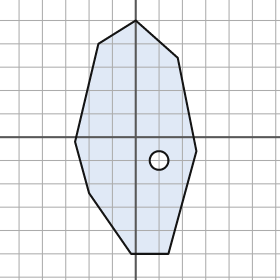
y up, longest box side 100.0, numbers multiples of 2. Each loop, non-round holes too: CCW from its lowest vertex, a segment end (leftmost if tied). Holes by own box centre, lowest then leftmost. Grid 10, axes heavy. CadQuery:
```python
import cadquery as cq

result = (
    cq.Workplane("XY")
    .moveTo(-2.0, -50.0)
    .lineTo(14.0, -50.0)
    .lineTo(26.0, -6.0)
    .lineTo(18.0, 34.0)
    .lineTo(0.0, 50.0)
    .lineTo(-16.0, 40.0)
    .lineTo(-26.0, -2.0)
    .lineTo(-20.0, -24.0)
    .close()
    .moveTo(10.0, -10.0)
    .circle(4.0)
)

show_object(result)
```